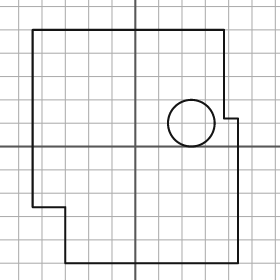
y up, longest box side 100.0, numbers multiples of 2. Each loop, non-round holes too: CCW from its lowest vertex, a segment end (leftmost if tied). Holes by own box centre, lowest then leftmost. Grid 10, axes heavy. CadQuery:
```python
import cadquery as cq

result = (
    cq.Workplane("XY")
    .moveTo(-30.0, -50.0)
    .lineTo(44.0, -50.0)
    .lineTo(44.0, 12.0)
    .lineTo(38.0, 12.0)
    .lineTo(38.0, 50.0)
    .lineTo(-44.0, 50.0)
    .lineTo(-44.0, -26.0)
    .lineTo(-30.0, -26.0)
    .close()
    .moveTo(24.0, 10.0)
    .circle(10.0)
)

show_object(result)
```